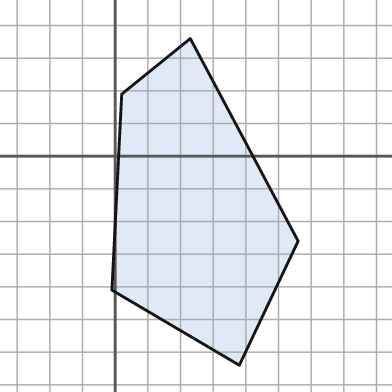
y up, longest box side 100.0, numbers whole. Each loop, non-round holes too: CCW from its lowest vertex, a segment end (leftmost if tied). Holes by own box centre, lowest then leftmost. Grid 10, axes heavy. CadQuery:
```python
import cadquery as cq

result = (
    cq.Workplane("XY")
    .moveTo(38.0, -64.0)
    .lineTo(56.0, -26.0)
    .lineTo(23.0, 36.0)
    .lineTo(2.0, 19.0)
    .lineTo(-1.0, -41.0)
    .close()
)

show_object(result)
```